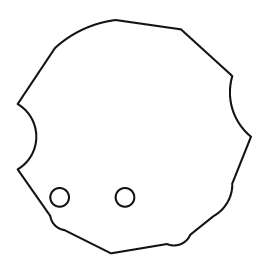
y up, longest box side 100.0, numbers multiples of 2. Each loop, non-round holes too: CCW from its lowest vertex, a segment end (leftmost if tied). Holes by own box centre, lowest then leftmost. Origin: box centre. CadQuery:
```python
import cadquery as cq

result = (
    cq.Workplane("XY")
    .moveTo(-10.0, -50.0)
    .lineTo(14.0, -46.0)
    .threePointArc((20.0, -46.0), (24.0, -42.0))
    .lineTo(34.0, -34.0)
    .threePointArc((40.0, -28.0), (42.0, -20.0))
    .lineTo(50.0, 0.0)
    .threePointArc((42.0, 12.0), (42.0, 26.0))
    .lineTo(20.0, 46.0)
    .lineTo(-8.0, 50.0)
    .threePointArc((-22.0, 46.0), (-34.0, 38.0))
    .lineTo(-50.0, 14.0)
    .threePointArc((-42.0, 0.0), (-50.0, -14.0))
    .lineTo(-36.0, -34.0)
    .threePointArc((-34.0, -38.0), (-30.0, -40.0))
    .close()
    .moveTo(-32.0, -26.0)
    .circle(4.0)
    .moveTo(-4.0, -26.0)
    .circle(4.0)
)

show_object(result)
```